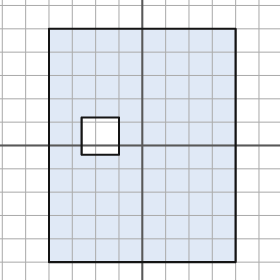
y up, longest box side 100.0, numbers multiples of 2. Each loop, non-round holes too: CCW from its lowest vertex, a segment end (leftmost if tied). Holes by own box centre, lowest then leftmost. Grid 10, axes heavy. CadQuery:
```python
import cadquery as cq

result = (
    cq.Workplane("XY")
    .moveTo(-40.0, -50.0)
    .lineTo(40.0, -50.0)
    .lineTo(40.0, 50.0)
    .lineTo(-40.0, 50.0)
    .close()
    .moveTo(-26.0, -4.0)
    .lineTo(-10.0, -4.0)
    .lineTo(-10.0, 12.0)
    .lineTo(-26.0, 12.0)
    .close()
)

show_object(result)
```